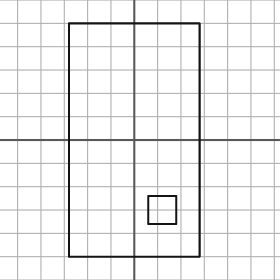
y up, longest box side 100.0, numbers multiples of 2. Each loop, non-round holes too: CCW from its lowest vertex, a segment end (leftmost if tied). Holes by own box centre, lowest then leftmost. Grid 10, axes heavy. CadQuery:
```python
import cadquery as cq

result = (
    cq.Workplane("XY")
    .moveTo(-28.0, -50.0)
    .lineTo(28.0, -50.0)
    .lineTo(28.0, 50.0)
    .lineTo(-28.0, 50.0)
    .close()
    .moveTo(6.0, -36.0)
    .lineTo(18.0, -36.0)
    .lineTo(18.0, -24.0)
    .lineTo(6.0, -24.0)
    .close()
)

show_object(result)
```